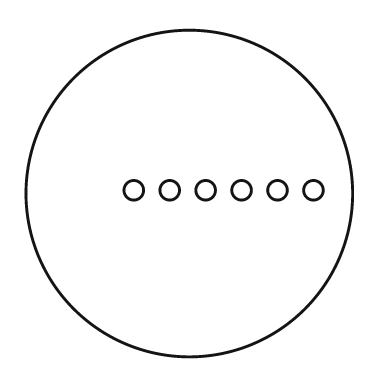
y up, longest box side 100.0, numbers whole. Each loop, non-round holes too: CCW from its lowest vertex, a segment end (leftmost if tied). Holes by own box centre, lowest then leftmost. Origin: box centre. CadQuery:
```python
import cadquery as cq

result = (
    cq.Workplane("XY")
    .moveTo(0.0, 0.0)
    .circle(50.0)
    .moveTo(-17.0, 1.0)
    .circle(3.0)
    .moveTo(-6.0, 1.0)
    .circle(3.0)
    .moveTo(5.0, 1.0)
    .circle(3.0)
    .moveTo(16.0, 1.0)
    .circle(3.0)
    .moveTo(27.0, 1.0)
    .circle(3.0)
    .moveTo(38.0, 1.0)
    .circle(3.0)
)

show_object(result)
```